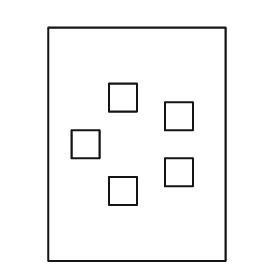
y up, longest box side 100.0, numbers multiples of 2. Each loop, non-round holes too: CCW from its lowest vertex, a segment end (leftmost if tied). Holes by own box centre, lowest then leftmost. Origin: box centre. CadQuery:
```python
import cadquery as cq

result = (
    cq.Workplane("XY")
    .moveTo(-38.0, -50.0)
    .lineTo(38.0, -50.0)
    .lineTo(38.0, 50.0)
    .lineTo(-38.0, 50.0)
    .close()
    .moveTo(-12.0, -26.0)
    .lineTo(0.0, -26.0)
    .lineTo(0.0, -14.0)
    .lineTo(-12.0, -14.0)
    .close()
    .moveTo(12.0, -18.0)
    .lineTo(24.0, -18.0)
    .lineTo(24.0, -6.0)
    .lineTo(12.0, -6.0)
    .close()
    .moveTo(-28.0, -6.0)
    .lineTo(-16.0, -6.0)
    .lineTo(-16.0, 6.0)
    .lineTo(-28.0, 6.0)
    .close()
    .moveTo(12.0, 6.0)
    .lineTo(24.0, 6.0)
    .lineTo(24.0, 18.0)
    .lineTo(12.0, 18.0)
    .close()
    .moveTo(-12.0, 14.0)
    .lineTo(0.0, 14.0)
    .lineTo(0.0, 26.0)
    .lineTo(-12.0, 26.0)
    .close()
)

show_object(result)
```